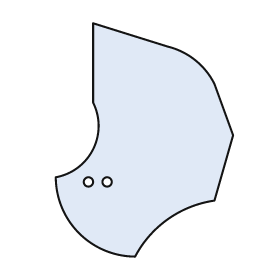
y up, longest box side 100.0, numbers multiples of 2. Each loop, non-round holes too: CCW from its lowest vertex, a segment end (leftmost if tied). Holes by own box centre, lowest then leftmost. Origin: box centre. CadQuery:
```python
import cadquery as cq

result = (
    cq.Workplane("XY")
    .moveTo(-4.0, -50.0)
    .threePointArc((10.0, -34.0), (30.0, -26.0))
    .lineTo(38.0, 2.0)
    .lineTo(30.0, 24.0)
    .threePointArc((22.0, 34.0), (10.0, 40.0))
    .lineTo(-22.0, 50.0)
    .lineTo(-22.0, 16.0)
    .threePointArc((-22.0, -4.0), (-38.0, -16.0))
    .threePointArc((-28.0, -40.0), (-4.0, -50.0))
    .close()
    .moveTo(-24.0, -18.0)
    .circle(2.0)
    .moveTo(-16.0, -18.0)
    .circle(2.0)
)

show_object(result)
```